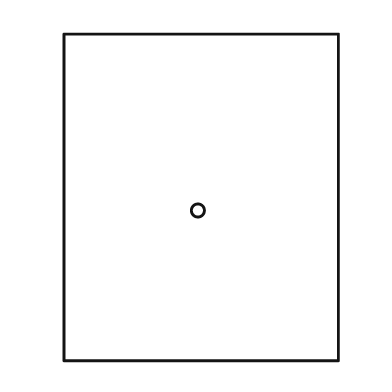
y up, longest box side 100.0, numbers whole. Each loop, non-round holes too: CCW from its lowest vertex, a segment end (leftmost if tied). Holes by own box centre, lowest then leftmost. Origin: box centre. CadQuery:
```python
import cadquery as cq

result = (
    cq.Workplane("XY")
    .moveTo(-42.0, -50.0)
    .lineTo(42.0, -50.0)
    .lineTo(42.0, 50.0)
    .lineTo(-42.0, 50.0)
    .close()
    .moveTo(-1.0, -4.0)
    .circle(2.0)
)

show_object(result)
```